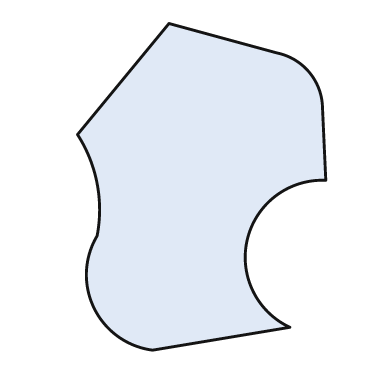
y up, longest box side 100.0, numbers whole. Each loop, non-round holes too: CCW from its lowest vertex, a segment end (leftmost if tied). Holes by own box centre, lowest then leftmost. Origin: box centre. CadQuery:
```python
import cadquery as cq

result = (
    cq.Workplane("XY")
    .moveTo(-15.0, -50.0)
    .lineTo(27.0, -43.0)
    .threePointArc((14.0, -16.0), (38.0, 2.0))
    .lineTo(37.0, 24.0)
    .threePointArc((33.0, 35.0), (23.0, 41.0))
    .lineTo(-10.0, 50.0)
    .lineTo(-38.0, 16.0)
    .threePointArc((-32.0, 1.0), (-32.0, -15.0))
    .threePointArc((-33.0, -37.0), (-15.0, -50.0))
    .close()
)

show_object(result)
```